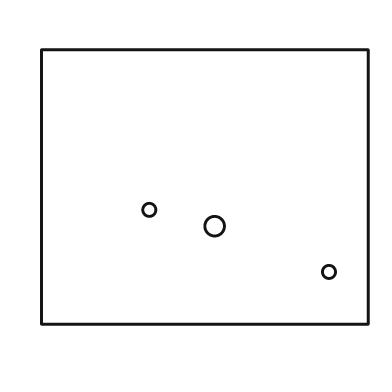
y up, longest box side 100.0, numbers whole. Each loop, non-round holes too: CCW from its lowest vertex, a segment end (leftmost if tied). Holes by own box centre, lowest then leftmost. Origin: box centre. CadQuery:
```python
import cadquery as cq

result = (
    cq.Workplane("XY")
    .moveTo(-50.0, -42.0)
    .lineTo(50.0, -42.0)
    .lineTo(50.0, 42.0)
    .lineTo(-50.0, 42.0)
    .close()
    .moveTo(38.0, -26.0)
    .circle(2.0)
    .moveTo(3.0, -12.0)
    .circle(3.0)
    .moveTo(-17.0, -7.0)
    .circle(2.0)
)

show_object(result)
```